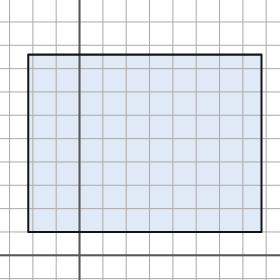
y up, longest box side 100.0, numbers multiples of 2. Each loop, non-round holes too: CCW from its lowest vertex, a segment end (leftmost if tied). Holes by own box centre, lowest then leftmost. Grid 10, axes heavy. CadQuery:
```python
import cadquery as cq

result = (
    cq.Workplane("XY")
    .moveTo(-22.0, 10.0)
    .lineTo(78.0, 10.0)
    .lineTo(78.0, 86.0)
    .lineTo(-22.0, 86.0)
    .close()
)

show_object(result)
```